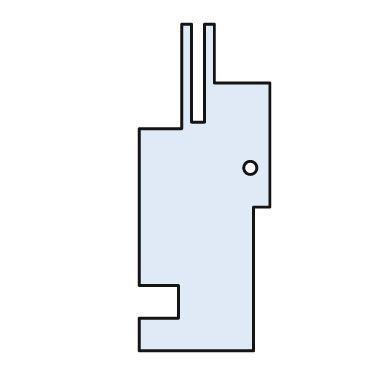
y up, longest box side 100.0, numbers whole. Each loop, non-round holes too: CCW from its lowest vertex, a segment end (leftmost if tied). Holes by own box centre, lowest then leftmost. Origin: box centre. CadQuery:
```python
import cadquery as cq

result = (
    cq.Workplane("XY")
    .moveTo(-20.0, -50.0)
    .lineTo(15.0, -50.0)
    .lineTo(15.0, -6.0)
    .lineTo(20.0, -6.0)
    .lineTo(20.0, 32.0)
    .lineTo(3.0, 32.0)
    .lineTo(3.0, 50.0)
    .lineTo(0.0, 50.0)
    .lineTo(0.0, 20.0)
    .lineTo(-4.0, 20.0)
    .lineTo(-4.0, 50.0)
    .lineTo(-7.0, 50.0)
    .lineTo(-7.0, 18.0)
    .lineTo(-20.0, 18.0)
    .lineTo(-20.0, -30.0)
    .lineTo(-8.0, -30.0)
    .lineTo(-8.0, -40.0)
    .lineTo(-20.0, -40.0)
    .close()
    .moveTo(14.0, 6.0)
    .circle(2.0)
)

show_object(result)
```